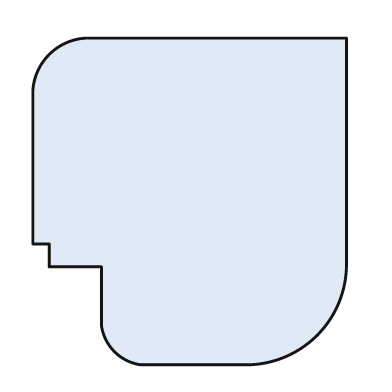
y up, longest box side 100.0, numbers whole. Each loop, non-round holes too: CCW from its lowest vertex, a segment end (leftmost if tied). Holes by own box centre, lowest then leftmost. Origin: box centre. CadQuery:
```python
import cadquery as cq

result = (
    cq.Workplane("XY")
    .moveTo(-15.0, -50.0)
    .lineTo(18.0, -50.0)
    .threePointArc((39.0, -41.0), (48.0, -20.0))
    .lineTo(48.0, 50.0)
    .lineTo(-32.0, 50.0)
    .threePointArc((-43.0, 45.0), (-48.0, 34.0))
    .lineTo(-48.0, -13.0)
    .lineTo(-43.0, -13.0)
    .lineTo(-43.0, -20.0)
    .lineTo(-27.0, -20.0)
    .lineTo(-27.0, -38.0)
    .threePointArc((-23.0, -46.0), (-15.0, -50.0))
    .close()
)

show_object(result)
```